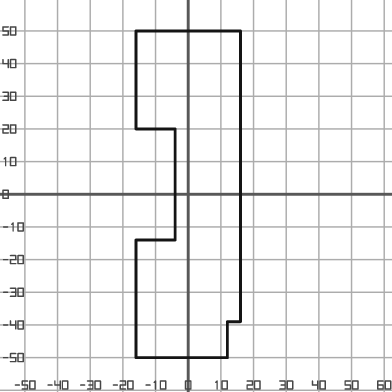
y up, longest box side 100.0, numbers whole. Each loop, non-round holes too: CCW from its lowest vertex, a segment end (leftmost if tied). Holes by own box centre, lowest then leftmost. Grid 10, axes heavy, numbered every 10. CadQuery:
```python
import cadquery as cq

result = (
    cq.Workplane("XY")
    .moveTo(-16.0, -50.0)
    .lineTo(12.0, -50.0)
    .lineTo(12.0, -39.0)
    .lineTo(16.0, -39.0)
    .lineTo(16.0, 50.0)
    .lineTo(-16.0, 50.0)
    .lineTo(-16.0, 20.0)
    .lineTo(-4.0, 20.0)
    .lineTo(-4.0, -14.0)
    .lineTo(-16.0, -14.0)
    .close()
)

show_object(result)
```